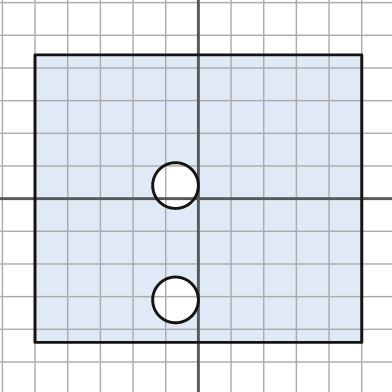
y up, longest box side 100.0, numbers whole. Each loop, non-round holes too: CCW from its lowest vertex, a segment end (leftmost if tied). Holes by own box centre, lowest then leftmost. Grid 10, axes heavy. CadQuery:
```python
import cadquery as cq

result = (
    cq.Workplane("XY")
    .moveTo(-50.0, -44.0)
    .lineTo(50.0, -44.0)
    .lineTo(50.0, 44.0)
    .lineTo(-50.0, 44.0)
    .close()
    .moveTo(-7.0, -31.0)
    .circle(7.0)
    .moveTo(-7.0, 4.0)
    .circle(7.0)
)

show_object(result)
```